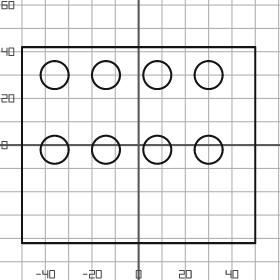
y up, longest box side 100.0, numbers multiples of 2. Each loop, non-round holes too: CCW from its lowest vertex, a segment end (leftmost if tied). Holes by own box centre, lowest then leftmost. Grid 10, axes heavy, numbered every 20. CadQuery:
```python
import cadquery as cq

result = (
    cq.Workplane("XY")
    .moveTo(-50.0, -42.0)
    .lineTo(50.0, -42.0)
    .lineTo(50.0, 42.0)
    .lineTo(-50.0, 42.0)
    .close()
    .moveTo(-36.0, -2.0)
    .circle(6.0)
    .moveTo(-14.0, -2.0)
    .circle(6.0)
    .moveTo(8.0, -2.0)
    .circle(6.0)
    .moveTo(30.0, -2.0)
    .circle(6.0)
    .moveTo(-36.0, 30.0)
    .circle(6.0)
    .moveTo(-14.0, 30.0)
    .circle(6.0)
    .moveTo(8.0, 30.0)
    .circle(6.0)
    .moveTo(30.0, 30.0)
    .circle(6.0)
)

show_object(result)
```